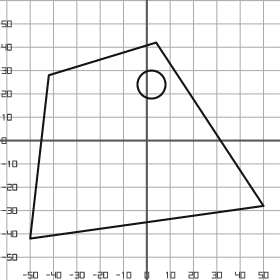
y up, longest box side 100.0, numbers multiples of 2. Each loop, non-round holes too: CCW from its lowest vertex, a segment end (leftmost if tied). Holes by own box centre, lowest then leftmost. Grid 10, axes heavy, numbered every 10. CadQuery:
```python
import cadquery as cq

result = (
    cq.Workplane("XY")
    .moveTo(-50.0, -42.0)
    .lineTo(50.0, -28.0)
    .lineTo(4.0, 42.0)
    .lineTo(-42.0, 28.0)
    .close()
    .moveTo(2.0, 24.0)
    .circle(6.0)
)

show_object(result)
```